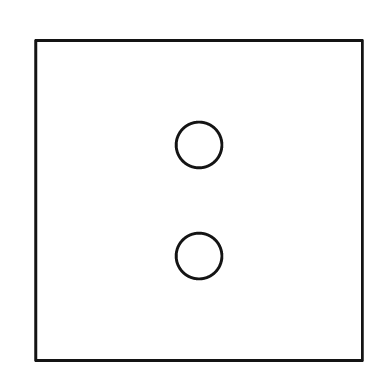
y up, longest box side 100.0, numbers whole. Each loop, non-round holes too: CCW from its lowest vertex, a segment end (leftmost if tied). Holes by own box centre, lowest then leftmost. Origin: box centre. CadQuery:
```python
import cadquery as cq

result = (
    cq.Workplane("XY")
    .moveTo(-50.0, -49.0)
    .lineTo(50.0, -49.0)
    .lineTo(50.0, 49.0)
    .lineTo(-50.0, 49.0)
    .close()
    .moveTo(0.0, -17.0)
    .circle(7.0)
    .moveTo(0.0, 17.0)
    .circle(7.0)
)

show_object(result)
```